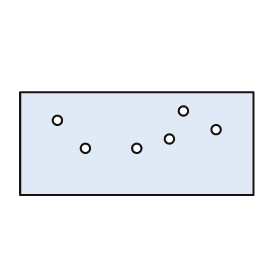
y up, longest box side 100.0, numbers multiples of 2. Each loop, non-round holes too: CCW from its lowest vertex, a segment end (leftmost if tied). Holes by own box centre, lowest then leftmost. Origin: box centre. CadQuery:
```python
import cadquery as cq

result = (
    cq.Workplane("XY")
    .moveTo(-50.0, -22.0)
    .lineTo(50.0, -22.0)
    .lineTo(50.0, 22.0)
    .lineTo(-50.0, 22.0)
    .close()
    .moveTo(-22.0, -2.0)
    .circle(2.0)
    .moveTo(0.0, -2.0)
    .circle(2.0)
    .moveTo(14.0, 2.0)
    .circle(2.0)
    .moveTo(34.0, 6.0)
    .circle(2.0)
    .moveTo(-34.0, 10.0)
    .circle(2.0)
    .moveTo(20.0, 14.0)
    .circle(2.0)
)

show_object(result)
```